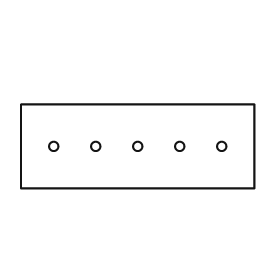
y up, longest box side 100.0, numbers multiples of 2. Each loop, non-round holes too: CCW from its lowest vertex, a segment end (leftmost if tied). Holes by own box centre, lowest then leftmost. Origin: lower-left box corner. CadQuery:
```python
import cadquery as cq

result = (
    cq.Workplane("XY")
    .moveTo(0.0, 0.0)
    .lineTo(100.0, 0.0)
    .lineTo(100.0, 36.0)
    .lineTo(0.0, 36.0)
    .close()
    .moveTo(14.0, 18.0)
    .circle(2.0)
    .moveTo(32.0, 18.0)
    .circle(2.0)
    .moveTo(50.0, 18.0)
    .circle(2.0)
    .moveTo(68.0, 18.0)
    .circle(2.0)
    .moveTo(86.0, 18.0)
    .circle(2.0)
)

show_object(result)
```